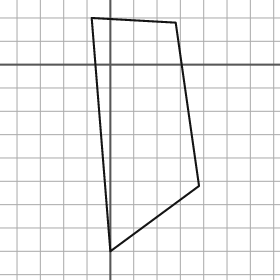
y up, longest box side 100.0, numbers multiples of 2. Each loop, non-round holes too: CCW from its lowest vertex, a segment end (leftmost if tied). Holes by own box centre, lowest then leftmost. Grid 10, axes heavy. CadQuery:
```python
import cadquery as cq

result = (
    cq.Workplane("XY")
    .moveTo(0.0, -80.0)
    .lineTo(38.0, -52.0)
    .lineTo(28.0, 18.0)
    .lineTo(-8.0, 20.0)
    .close()
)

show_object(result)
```